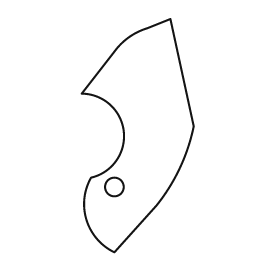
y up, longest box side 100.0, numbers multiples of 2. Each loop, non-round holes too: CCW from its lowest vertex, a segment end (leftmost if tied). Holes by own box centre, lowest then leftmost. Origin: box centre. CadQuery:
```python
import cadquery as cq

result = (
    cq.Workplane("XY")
    .moveTo(-10.0, -50.0)
    .lineTo(8.0, -30.0)
    .threePointArc((18.0, -14.0), (24.0, 4.0))
    .lineTo(14.0, 50.0)
    .lineTo(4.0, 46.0)
    .threePointArc((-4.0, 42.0), (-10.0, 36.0))
    .lineTo(-24.0, 18.0)
    .threePointArc((-6.0, 2.0), (-20.0, -18.0))
    .threePointArc((-22.0, -36.0), (-10.0, -50.0))
    .close()
    .moveTo(-10.0, -22.0)
    .circle(4.0)
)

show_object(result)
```